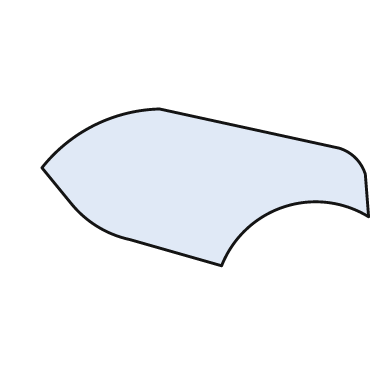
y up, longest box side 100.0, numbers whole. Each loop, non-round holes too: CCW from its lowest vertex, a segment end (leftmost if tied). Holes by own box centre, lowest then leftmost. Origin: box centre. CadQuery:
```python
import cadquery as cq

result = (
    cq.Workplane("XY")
    .moveTo(5.0, -24.0)
    .threePointArc((24.0, -6.0), (50.0, -9.0))
    .lineTo(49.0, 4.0)
    .threePointArc((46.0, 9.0), (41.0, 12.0))
    .lineTo(-14.0, 24.0)
    .threePointArc((-34.0, 19.0), (-50.0, 6.0))
    .lineTo(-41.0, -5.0)
    .threePointArc((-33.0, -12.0), (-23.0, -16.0))
    .close()
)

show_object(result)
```